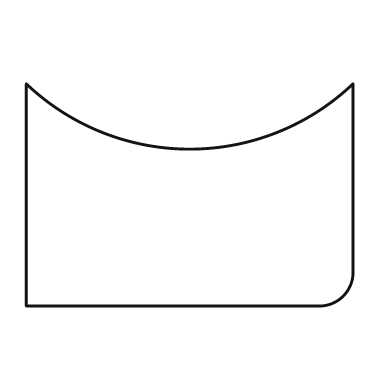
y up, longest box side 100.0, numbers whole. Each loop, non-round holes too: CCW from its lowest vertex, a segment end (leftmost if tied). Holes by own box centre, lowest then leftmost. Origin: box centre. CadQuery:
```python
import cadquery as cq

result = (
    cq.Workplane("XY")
    .moveTo(-50.0, -34.0)
    .lineTo(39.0, -34.0)
    .threePointArc((47.0, -31.0), (50.0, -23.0))
    .lineTo(50.0, 34.0)
    .threePointArc((0.0, 14.0), (-50.0, 34.0))
    .close()
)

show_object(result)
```